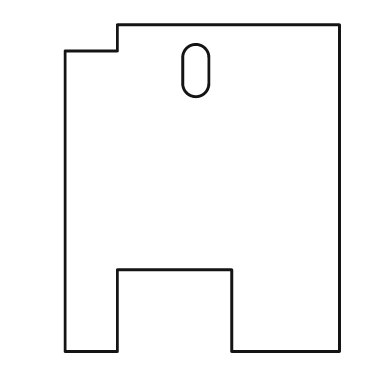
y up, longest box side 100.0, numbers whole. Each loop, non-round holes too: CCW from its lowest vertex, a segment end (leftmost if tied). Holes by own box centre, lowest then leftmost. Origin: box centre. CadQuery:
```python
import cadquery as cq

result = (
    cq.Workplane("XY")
    .moveTo(-42.0, -50.0)
    .lineTo(-26.0, -50.0)
    .lineTo(-26.0, -25.0)
    .lineTo(9.0, -25.0)
    .lineTo(9.0, -50.0)
    .lineTo(42.0, -50.0)
    .lineTo(42.0, 50.0)
    .lineTo(-26.0, 50.0)
    .lineTo(-26.0, 42.0)
    .lineTo(-42.0, 42.0)
    .close()
    .moveTo(-6.0, 32.0)
    .threePointArc((-2.0, 28.0), (2.0, 32.0))
    .lineTo(2.0, 40.0)
    .threePointArc((-2.0, 44.0), (-6.0, 40.0))
    .close()
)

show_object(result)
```